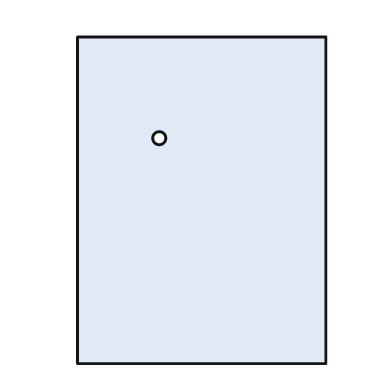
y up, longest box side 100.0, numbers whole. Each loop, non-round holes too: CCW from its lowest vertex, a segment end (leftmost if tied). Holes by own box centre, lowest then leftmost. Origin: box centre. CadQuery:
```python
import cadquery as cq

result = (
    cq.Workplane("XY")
    .moveTo(-38.0, -50.0)
    .lineTo(38.0, -50.0)
    .lineTo(38.0, 50.0)
    .lineTo(-38.0, 50.0)
    .close()
    .moveTo(-13.0, 19.0)
    .circle(2.0)
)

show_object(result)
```